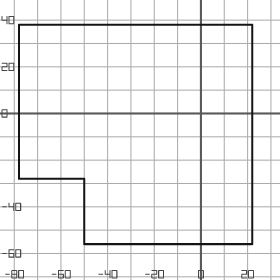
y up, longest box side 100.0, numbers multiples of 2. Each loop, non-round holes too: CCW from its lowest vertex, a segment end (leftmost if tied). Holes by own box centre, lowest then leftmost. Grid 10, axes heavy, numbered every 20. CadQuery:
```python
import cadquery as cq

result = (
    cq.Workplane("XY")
    .moveTo(-50.0, -56.0)
    .lineTo(22.0, -56.0)
    .lineTo(22.0, 38.0)
    .lineTo(-78.0, 38.0)
    .lineTo(-78.0, -28.0)
    .lineTo(-50.0, -28.0)
    .close()
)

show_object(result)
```